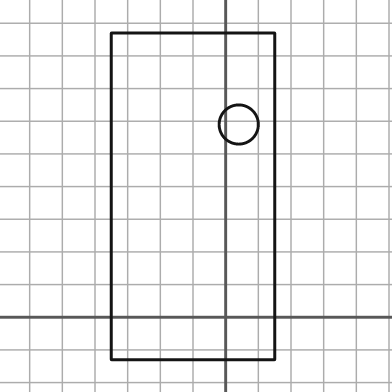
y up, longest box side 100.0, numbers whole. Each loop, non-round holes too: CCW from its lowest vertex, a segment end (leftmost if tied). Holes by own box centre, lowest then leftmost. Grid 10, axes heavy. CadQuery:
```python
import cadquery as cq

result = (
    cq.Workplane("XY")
    .moveTo(-35.0, -13.0)
    .lineTo(15.0, -13.0)
    .lineTo(15.0, 87.0)
    .lineTo(-35.0, 87.0)
    .close()
    .moveTo(4.0, 59.0)
    .circle(6.0)
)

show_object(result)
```